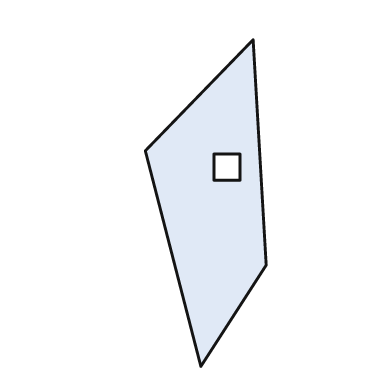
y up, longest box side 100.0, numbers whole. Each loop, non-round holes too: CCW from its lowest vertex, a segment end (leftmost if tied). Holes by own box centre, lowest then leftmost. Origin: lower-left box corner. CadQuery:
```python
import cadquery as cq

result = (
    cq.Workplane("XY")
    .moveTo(17.0, 0.0)
    .lineTo(37.0, 31.0)
    .lineTo(33.0, 100.0)
    .lineTo(0.0, 66.0)
    .close()
    .moveTo(21.0, 57.0)
    .lineTo(29.0, 57.0)
    .lineTo(29.0, 65.0)
    .lineTo(21.0, 65.0)
    .close()
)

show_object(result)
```